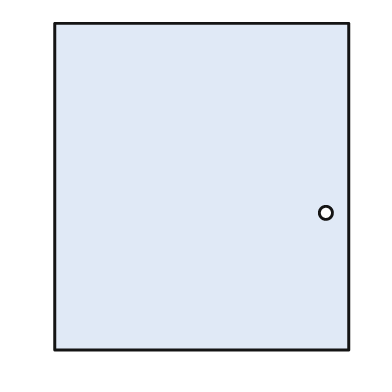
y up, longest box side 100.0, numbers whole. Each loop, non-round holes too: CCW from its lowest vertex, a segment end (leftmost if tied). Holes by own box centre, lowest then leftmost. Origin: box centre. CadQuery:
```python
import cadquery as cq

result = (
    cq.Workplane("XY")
    .moveTo(-45.0, -50.0)
    .lineTo(45.0, -50.0)
    .lineTo(45.0, 50.0)
    .lineTo(-45.0, 50.0)
    .close()
    .moveTo(38.0, -8.0)
    .circle(2.0)
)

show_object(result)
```